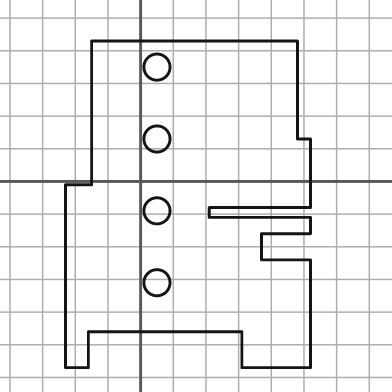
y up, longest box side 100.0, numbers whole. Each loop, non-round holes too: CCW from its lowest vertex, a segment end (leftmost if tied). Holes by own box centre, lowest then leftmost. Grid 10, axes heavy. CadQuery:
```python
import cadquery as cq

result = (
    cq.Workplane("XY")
    .moveTo(-23.0, -57.0)
    .lineTo(-16.0, -57.0)
    .lineTo(-16.0, -46.0)
    .lineTo(31.0, -46.0)
    .lineTo(31.0, -57.0)
    .lineTo(52.0, -57.0)
    .lineTo(52.0, -24.0)
    .lineTo(37.0, -24.0)
    .lineTo(37.0, -16.0)
    .lineTo(52.0, -16.0)
    .lineTo(52.0, -11.0)
    .lineTo(21.0, -11.0)
    .lineTo(21.0, -8.0)
    .lineTo(52.0, -8.0)
    .lineTo(52.0, 13.0)
    .lineTo(48.0, 13.0)
    .lineTo(48.0, 43.0)
    .lineTo(-15.0, 43.0)
    .lineTo(-15.0, -1.0)
    .lineTo(-23.0, -1.0)
    .close()
    .moveTo(5.0, -31.0)
    .circle(4.0)
    .moveTo(5.0, -9.0)
    .circle(4.0)
    .moveTo(5.0, 13.0)
    .circle(4.0)
    .moveTo(5.0, 35.0)
    .circle(4.0)
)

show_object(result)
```